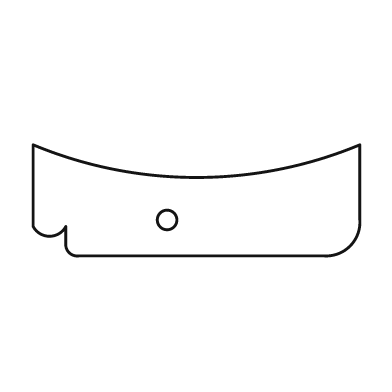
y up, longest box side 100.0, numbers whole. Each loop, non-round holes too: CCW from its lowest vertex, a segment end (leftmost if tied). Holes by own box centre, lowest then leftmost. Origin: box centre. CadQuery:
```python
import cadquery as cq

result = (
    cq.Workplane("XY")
    .moveTo(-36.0, -17.0)
    .lineTo(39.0, -17.0)
    .threePointArc((47.0, -14.0), (50.0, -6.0))
    .lineTo(50.0, 17.0)
    .threePointArc((0.0, 7.0), (-50.0, 17.0))
    .lineTo(-50.0, -8.0)
    .threePointArc((-45.0, -11.0), (-40.0, -8.0))
    .lineTo(-40.0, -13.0)
    .threePointArc((-39.0, -16.0), (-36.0, -17.0))
    .close()
    .moveTo(-9.0, -6.0)
    .circle(3.0)
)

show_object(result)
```